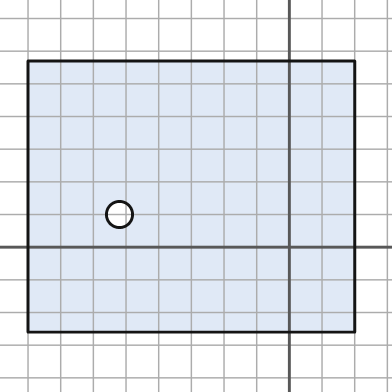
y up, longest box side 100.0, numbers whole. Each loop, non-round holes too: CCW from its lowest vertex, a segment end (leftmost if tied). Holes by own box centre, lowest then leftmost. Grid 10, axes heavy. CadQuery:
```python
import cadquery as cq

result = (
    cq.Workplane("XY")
    .moveTo(-80.0, -26.0)
    .lineTo(20.0, -26.0)
    .lineTo(20.0, 57.0)
    .lineTo(-80.0, 57.0)
    .close()
    .moveTo(-52.0, 10.0)
    .circle(4.0)
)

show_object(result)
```